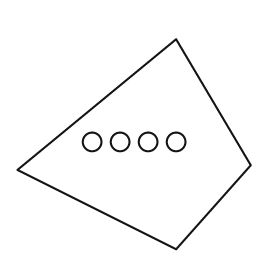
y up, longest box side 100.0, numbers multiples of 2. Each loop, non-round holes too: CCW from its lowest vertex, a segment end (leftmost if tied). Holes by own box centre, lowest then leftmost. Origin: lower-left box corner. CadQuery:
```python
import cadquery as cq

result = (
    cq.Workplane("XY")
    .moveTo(68.0, 0.0)
    .lineTo(100.0, 36.0)
    .lineTo(68.0, 90.0)
    .lineTo(0.0, 34.0)
    .close()
    .moveTo(32.0, 46.0)
    .circle(4.0)
    .moveTo(44.0, 46.0)
    .circle(4.0)
    .moveTo(56.0, 46.0)
    .circle(4.0)
    .moveTo(68.0, 46.0)
    .circle(4.0)
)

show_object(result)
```